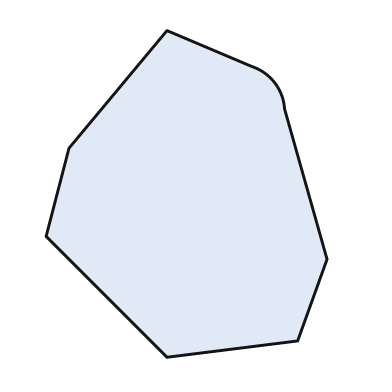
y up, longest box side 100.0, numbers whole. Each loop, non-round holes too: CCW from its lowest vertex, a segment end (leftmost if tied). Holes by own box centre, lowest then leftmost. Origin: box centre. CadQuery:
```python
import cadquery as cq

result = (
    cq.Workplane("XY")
    .moveTo(-6.0, -50.0)
    .lineTo(34.0, -45.0)
    .lineTo(43.0, -20.0)
    .lineTo(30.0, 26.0)
    .threePointArc((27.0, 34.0), (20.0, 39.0))
    .lineTo(-6.0, 50.0)
    .lineTo(-36.0, 14.0)
    .lineTo(-43.0, -13.0)
    .close()
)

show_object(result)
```